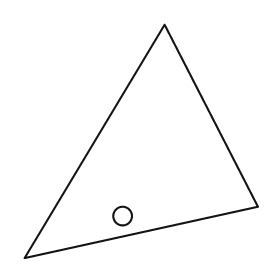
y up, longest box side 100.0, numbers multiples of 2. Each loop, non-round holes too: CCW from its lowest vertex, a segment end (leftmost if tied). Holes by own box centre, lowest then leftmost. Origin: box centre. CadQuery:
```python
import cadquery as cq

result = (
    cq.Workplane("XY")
    .moveTo(-50.0, -50.0)
    .lineTo(50.0, -28.0)
    .lineTo(10.0, 50.0)
    .close()
    .moveTo(-8.0, -32.0)
    .circle(4.0)
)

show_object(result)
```